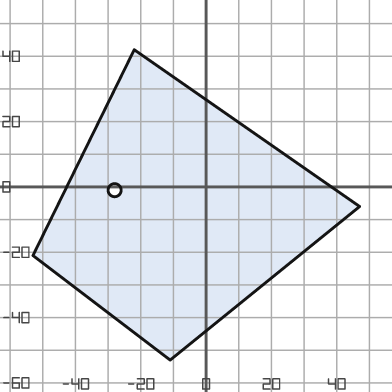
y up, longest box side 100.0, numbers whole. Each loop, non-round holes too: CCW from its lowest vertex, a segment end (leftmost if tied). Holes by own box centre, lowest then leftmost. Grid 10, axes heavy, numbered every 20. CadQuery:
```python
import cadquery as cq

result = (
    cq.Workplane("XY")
    .moveTo(-11.0, -53.0)
    .lineTo(47.0, -6.0)
    .lineTo(-22.0, 42.0)
    .lineTo(-53.0, -21.0)
    .close()
    .moveTo(-28.0, -1.0)
    .circle(2.0)
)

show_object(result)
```